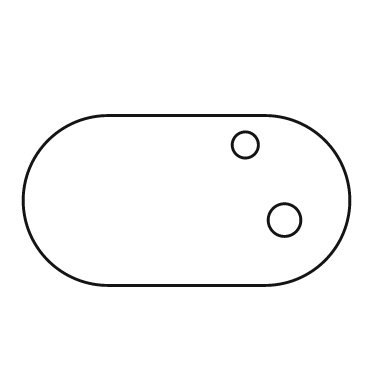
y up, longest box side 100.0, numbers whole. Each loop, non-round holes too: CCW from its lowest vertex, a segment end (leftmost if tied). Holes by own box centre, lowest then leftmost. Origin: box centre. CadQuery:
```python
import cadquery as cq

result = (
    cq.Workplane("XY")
    .moveTo(-24.0, -26.0)
    .lineTo(24.0, -26.0)
    .threePointArc((50.0, 0.0), (24.0, 26.0))
    .lineTo(-24.0, 26.0)
    .threePointArc((-50.0, 0.0), (-24.0, -26.0))
    .close()
    .moveTo(30.0, -6.0)
    .circle(5.0)
    .moveTo(18.0, 17.0)
    .circle(4.0)
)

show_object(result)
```